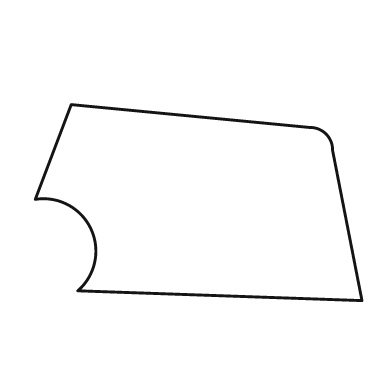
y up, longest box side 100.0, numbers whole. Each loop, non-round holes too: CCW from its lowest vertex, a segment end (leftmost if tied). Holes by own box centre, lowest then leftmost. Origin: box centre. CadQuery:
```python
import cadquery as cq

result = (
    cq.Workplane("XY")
    .moveTo(50.0, -30.0)
    .lineTo(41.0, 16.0)
    .threePointArc((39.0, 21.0), (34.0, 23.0))
    .lineTo(-39.0, 30.0)
    .lineTo(-50.0, 1.0)
    .threePointArc((-33.0, -8.0), (-37.0, -27.0))
    .close()
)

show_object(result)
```